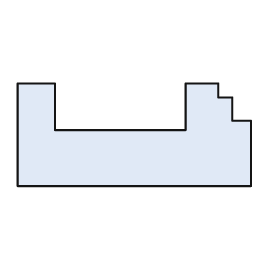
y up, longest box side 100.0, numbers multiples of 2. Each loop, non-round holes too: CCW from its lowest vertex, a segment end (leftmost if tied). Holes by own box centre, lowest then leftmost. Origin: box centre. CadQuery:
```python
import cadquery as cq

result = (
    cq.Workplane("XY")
    .moveTo(-50.0, -22.0)
    .lineTo(50.0, -22.0)
    .lineTo(50.0, 6.0)
    .lineTo(42.0, 6.0)
    .lineTo(42.0, 16.0)
    .lineTo(36.0, 16.0)
    .lineTo(36.0, 22.0)
    .lineTo(22.0, 22.0)
    .lineTo(22.0, 2.0)
    .lineTo(-34.0, 2.0)
    .lineTo(-34.0, 22.0)
    .lineTo(-50.0, 22.0)
    .close()
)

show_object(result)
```